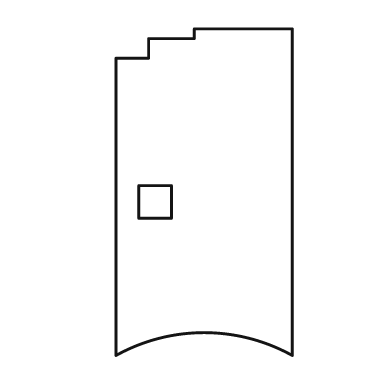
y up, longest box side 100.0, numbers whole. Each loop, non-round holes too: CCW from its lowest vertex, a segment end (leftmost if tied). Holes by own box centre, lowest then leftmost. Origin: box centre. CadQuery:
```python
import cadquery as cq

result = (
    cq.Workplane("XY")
    .moveTo(-27.0, -50.0)
    .threePointArc((0.0, -43.0), (27.0, -50.0))
    .lineTo(27.0, 50.0)
    .lineTo(-3.0, 50.0)
    .lineTo(-3.0, 47.0)
    .lineTo(-17.0, 47.0)
    .lineTo(-17.0, 41.0)
    .lineTo(-27.0, 41.0)
    .close()
    .moveTo(-20.0, -8.0)
    .lineTo(-10.0, -8.0)
    .lineTo(-10.0, 2.0)
    .lineTo(-20.0, 2.0)
    .close()
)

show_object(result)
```